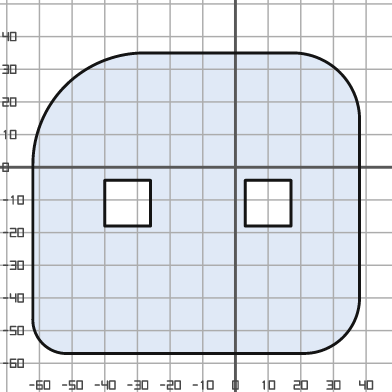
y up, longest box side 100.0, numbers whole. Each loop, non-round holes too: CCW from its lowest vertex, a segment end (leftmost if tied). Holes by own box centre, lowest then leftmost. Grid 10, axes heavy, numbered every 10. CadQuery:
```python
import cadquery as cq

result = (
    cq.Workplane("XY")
    .moveTo(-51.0, -57.0)
    .lineTo(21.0, -57.0)
    .threePointArc((33.0, -52.0), (38.0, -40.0))
    .lineTo(38.0, 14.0)
    .threePointArc((32.0, 29.0), (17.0, 35.0))
    .lineTo(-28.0, 35.0)
    .threePointArc((-52.0, 25.0), (-62.0, 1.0))
    .lineTo(-62.0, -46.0)
    .threePointArc((-59.0, -54.0), (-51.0, -57.0))
    .close()
    .moveTo(-40.0, -18.0)
    .lineTo(-26.0, -18.0)
    .lineTo(-26.0, -4.0)
    .lineTo(-40.0, -4.0)
    .close()
    .moveTo(3.0, -18.0)
    .lineTo(17.0, -18.0)
    .lineTo(17.0, -4.0)
    .lineTo(3.0, -4.0)
    .close()
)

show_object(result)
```